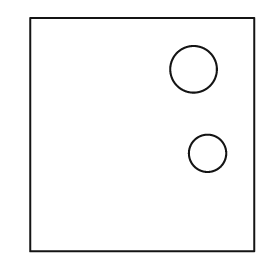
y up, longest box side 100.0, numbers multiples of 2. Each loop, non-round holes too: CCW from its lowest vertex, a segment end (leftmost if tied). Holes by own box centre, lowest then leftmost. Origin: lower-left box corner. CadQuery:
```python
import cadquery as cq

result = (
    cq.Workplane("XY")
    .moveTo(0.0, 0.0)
    .lineTo(96.0, 0.0)
    .lineTo(96.0, 100.0)
    .lineTo(0.0, 100.0)
    .close()
    .moveTo(76.0, 42.0)
    .circle(8.0)
    .moveTo(70.0, 78.0)
    .circle(10.0)
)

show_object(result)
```